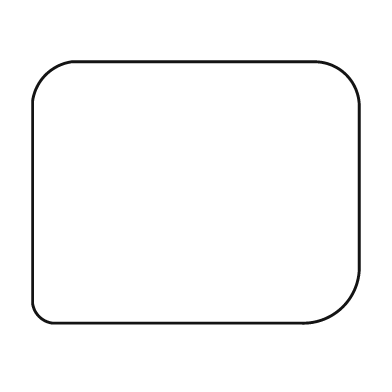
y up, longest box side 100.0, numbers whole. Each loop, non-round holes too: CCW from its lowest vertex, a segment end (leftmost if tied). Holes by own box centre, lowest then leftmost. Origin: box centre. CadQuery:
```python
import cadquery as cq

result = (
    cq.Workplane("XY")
    .moveTo(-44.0, -40.0)
    .lineTo(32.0, -40.0)
    .threePointArc((45.0, -35.0), (50.0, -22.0))
    .lineTo(50.0, 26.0)
    .threePointArc((46.0, 36.0), (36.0, 40.0))
    .lineTo(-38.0, 40.0)
    .threePointArc((-46.0, 36.0), (-50.0, 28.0))
    .lineTo(-50.0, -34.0)
    .threePointArc((-48.0, -38.0), (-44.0, -40.0))
    .close()
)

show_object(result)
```